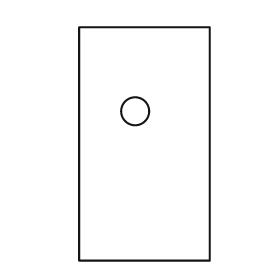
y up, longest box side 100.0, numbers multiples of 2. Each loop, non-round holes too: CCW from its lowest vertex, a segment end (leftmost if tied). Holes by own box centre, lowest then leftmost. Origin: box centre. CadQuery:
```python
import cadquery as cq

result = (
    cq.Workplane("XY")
    .moveTo(-28.0, -50.0)
    .lineTo(28.0, -50.0)
    .lineTo(28.0, 50.0)
    .lineTo(-28.0, 50.0)
    .close()
    .moveTo(-4.0, 14.0)
    .circle(6.0)
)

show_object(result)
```